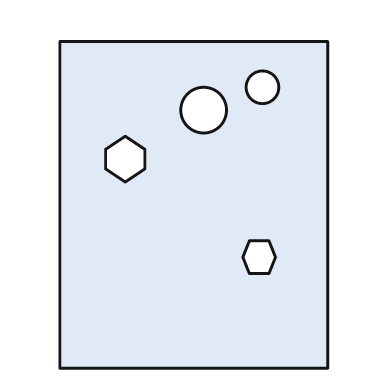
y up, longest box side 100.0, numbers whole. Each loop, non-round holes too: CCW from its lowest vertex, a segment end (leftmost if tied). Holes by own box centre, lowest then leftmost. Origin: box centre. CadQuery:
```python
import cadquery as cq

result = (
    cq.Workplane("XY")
    .moveTo(-41.0, -50.0)
    .lineTo(41.0, -50.0)
    .lineTo(41.0, 50.0)
    .lineTo(-41.0, 50.0)
    .close()
    .moveTo(17.0, -21.0)
    .lineTo(23.0, -21.0)
    .lineTo(25.0, -16.0)
    .lineTo(23.0, -11.0)
    .lineTo(17.0, -11.0)
    .lineTo(15.0, -16.0)
    .close()
    .moveTo(-21.0, 7.0)
    .lineTo(-15.0, 11.0)
    .lineTo(-15.0, 17.0)
    .lineTo(-21.0, 21.0)
    .lineTo(-27.0, 17.0)
    .lineTo(-27.0, 11.0)
    .close()
    .moveTo(3.0, 29.0)
    .circle(7.0)
    .moveTo(21.0, 36.0)
    .circle(5.0)
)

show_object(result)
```